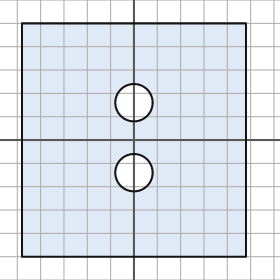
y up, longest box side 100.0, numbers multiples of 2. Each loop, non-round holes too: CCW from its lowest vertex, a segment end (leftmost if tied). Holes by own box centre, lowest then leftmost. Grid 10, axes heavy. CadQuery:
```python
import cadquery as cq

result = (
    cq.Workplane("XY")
    .moveTo(-48.0, -50.0)
    .lineTo(48.0, -50.0)
    .lineTo(48.0, 50.0)
    .lineTo(-48.0, 50.0)
    .close()
    .moveTo(0.0, -14.0)
    .circle(8.0)
    .moveTo(0.0, 16.0)
    .circle(8.0)
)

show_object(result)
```